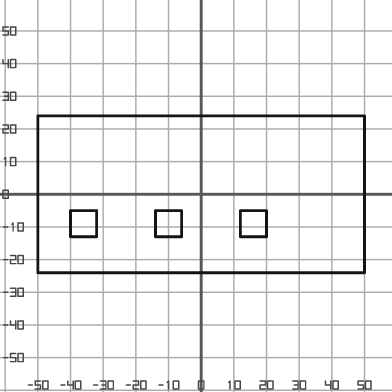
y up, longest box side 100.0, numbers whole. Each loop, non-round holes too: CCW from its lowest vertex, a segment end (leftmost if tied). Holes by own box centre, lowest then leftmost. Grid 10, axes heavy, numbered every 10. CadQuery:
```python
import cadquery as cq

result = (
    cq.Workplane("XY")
    .moveTo(-50.0, -24.0)
    .lineTo(50.0, -24.0)
    .lineTo(50.0, 24.0)
    .lineTo(-50.0, 24.0)
    .close()
    .moveTo(-40.0, -13.0)
    .lineTo(-32.0, -13.0)
    .lineTo(-32.0, -5.0)
    .lineTo(-40.0, -5.0)
    .close()
    .moveTo(-14.0, -13.0)
    .lineTo(-6.0, -13.0)
    .lineTo(-6.0, -5.0)
    .lineTo(-14.0, -5.0)
    .close()
    .moveTo(12.0, -13.0)
    .lineTo(20.0, -13.0)
    .lineTo(20.0, -5.0)
    .lineTo(12.0, -5.0)
    .close()
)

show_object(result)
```